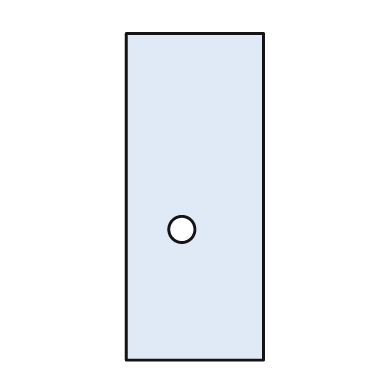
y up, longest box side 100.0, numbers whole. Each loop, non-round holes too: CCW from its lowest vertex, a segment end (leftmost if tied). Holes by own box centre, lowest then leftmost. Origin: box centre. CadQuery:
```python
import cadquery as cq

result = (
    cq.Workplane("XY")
    .moveTo(-21.0, -50.0)
    .lineTo(21.0, -50.0)
    .lineTo(21.0, 50.0)
    .lineTo(-21.0, 50.0)
    .close()
    .moveTo(-4.0, -10.0)
    .circle(4.0)
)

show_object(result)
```